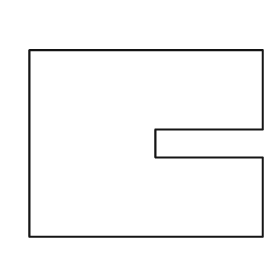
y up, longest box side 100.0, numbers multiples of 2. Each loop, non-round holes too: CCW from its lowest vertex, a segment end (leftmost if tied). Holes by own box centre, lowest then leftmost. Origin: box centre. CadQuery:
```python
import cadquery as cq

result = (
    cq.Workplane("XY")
    .moveTo(-50.0, -40.0)
    .lineTo(50.0, -40.0)
    .lineTo(50.0, -6.0)
    .lineTo(4.0, -6.0)
    .lineTo(4.0, 6.0)
    .lineTo(50.0, 6.0)
    .lineTo(50.0, 40.0)
    .lineTo(-50.0, 40.0)
    .close()
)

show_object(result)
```